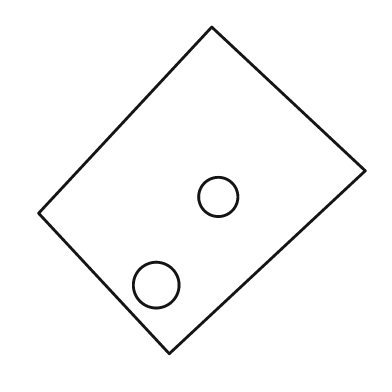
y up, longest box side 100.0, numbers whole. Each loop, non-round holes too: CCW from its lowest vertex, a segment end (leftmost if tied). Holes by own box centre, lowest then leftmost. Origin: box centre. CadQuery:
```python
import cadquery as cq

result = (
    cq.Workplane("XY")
    .moveTo(-10.0, -50.0)
    .lineTo(50.0, 6.0)
    .lineTo(3.0, 50.0)
    .lineTo(-50.0, -7.0)
    .close()
    .moveTo(-14.0, -29.0)
    .circle(7.0)
    .moveTo(5.0, -2.0)
    .circle(6.0)
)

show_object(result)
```